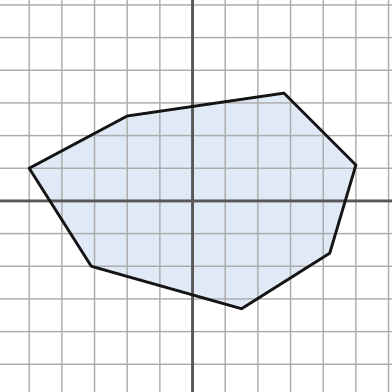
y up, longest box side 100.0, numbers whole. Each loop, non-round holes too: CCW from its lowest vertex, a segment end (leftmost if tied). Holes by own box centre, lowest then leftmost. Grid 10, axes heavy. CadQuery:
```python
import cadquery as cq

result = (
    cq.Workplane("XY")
    .moveTo(15.0, -33.0)
    .lineTo(42.0, -16.0)
    .lineTo(50.0, 11.0)
    .lineTo(28.0, 33.0)
    .lineTo(-20.0, 26.0)
    .lineTo(-50.0, 10.0)
    .lineTo(-31.0, -20.0)
    .close()
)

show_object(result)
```